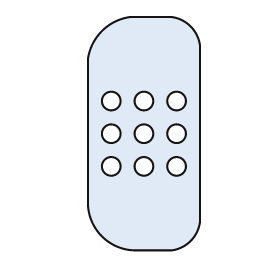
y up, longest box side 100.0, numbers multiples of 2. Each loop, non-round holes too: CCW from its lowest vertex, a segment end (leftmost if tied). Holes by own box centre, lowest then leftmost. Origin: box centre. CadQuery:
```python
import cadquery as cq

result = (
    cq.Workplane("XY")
    .moveTo(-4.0, -50.0)
    .lineTo(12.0, -50.0)
    .threePointArc((20.0, -46.0), (24.0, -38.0))
    .lineTo(24.0, 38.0)
    .threePointArc((20.0, 46.0), (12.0, 50.0))
    .lineTo(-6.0, 50.0)
    .threePointArc((-18.0, 44.0), (-24.0, 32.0))
    .lineTo(-24.0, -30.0)
    .threePointArc((-18.0, -44.0), (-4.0, -50.0))
    .close()
    .moveTo(-14.0, -14.0)
    .circle(4.0)
    .moveTo(0.0, -14.0)
    .circle(4.0)
    .moveTo(14.0, -14.0)
    .circle(4.0)
    .moveTo(-14.0, 0.0)
    .circle(4.0)
    .moveTo(0.0, 0.0)
    .circle(4.0)
    .moveTo(14.0, 0.0)
    .circle(4.0)
    .moveTo(-14.0, 14.0)
    .circle(4.0)
    .moveTo(0.0, 14.0)
    .circle(4.0)
    .moveTo(14.0, 14.0)
    .circle(4.0)
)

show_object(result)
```